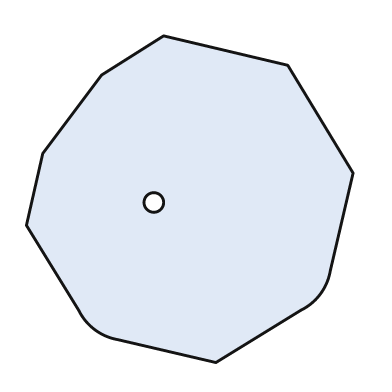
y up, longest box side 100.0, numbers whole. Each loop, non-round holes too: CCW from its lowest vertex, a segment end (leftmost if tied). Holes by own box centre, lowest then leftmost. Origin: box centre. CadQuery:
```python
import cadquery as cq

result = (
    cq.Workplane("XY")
    .moveTo(8.0, -50.0)
    .lineTo(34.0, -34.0)
    .threePointArc((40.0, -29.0), (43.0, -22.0))
    .lineTo(50.0, 8.0)
    .lineTo(30.0, 41.0)
    .lineTo(-8.0, 50.0)
    .lineTo(-27.0, 38.0)
    .lineTo(-45.0, 14.0)
    .lineTo(-50.0, -8.0)
    .lineTo(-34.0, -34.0)
    .threePointArc((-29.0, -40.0), (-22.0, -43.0))
    .close()
    .moveTo(-11.0, -1.0)
    .circle(3.0)
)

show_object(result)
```